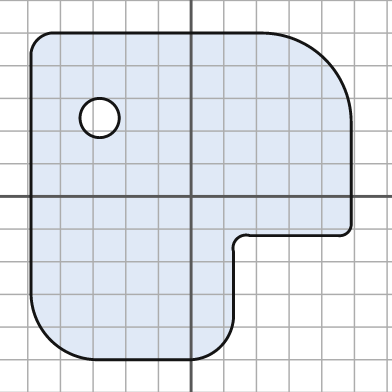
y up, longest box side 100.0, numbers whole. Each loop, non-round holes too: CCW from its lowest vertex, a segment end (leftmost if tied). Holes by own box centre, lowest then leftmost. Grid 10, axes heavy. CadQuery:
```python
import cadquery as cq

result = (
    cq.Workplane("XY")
    .moveTo(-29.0, -50.0)
    .lineTo(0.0, -50.0)
    .threePointArc((9.0, -46.0), (13.0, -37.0))
    .lineTo(13.0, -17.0)
    .threePointArc((14.0, -13.0), (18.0, -12.0))
    .lineTo(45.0, -12.0)
    .threePointArc((48.0, -11.0), (49.0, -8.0))
    .lineTo(49.0, 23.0)
    .threePointArc((41.0, 42.0), (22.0, 50.0))
    .lineTo(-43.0, 50.0)
    .threePointArc((-47.0, 48.0), (-49.0, 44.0))
    .lineTo(-49.0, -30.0)
    .threePointArc((-43.0, -44.0), (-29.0, -50.0))
    .close()
    .moveTo(-28.0, 24.0)
    .circle(6.0)
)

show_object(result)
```